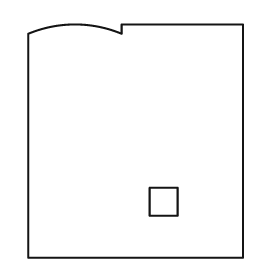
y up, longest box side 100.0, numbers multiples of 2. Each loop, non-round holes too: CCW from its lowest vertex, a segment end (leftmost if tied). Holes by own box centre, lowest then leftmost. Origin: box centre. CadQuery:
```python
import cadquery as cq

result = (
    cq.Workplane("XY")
    .moveTo(-46.0, -50.0)
    .lineTo(46.0, -50.0)
    .lineTo(46.0, 50.0)
    .lineTo(-6.0, 50.0)
    .lineTo(-6.0, 46.0)
    .threePointArc((-26.0, 50.0), (-46.0, 46.0))
    .close()
    .moveTo(6.0, -32.0)
    .lineTo(18.0, -32.0)
    .lineTo(18.0, -20.0)
    .lineTo(6.0, -20.0)
    .close()
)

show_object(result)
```